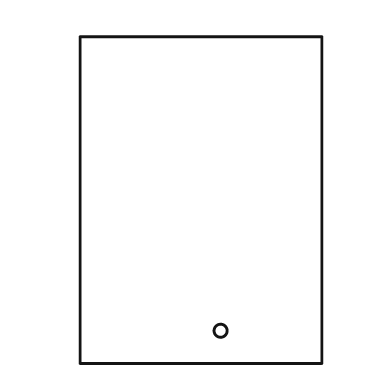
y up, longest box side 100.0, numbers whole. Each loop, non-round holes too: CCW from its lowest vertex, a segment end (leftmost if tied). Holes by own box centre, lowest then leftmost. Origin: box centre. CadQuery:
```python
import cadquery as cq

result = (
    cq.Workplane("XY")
    .moveTo(-37.0, -50.0)
    .lineTo(37.0, -50.0)
    .lineTo(37.0, 50.0)
    .lineTo(-37.0, 50.0)
    .close()
    .moveTo(6.0, -40.0)
    .circle(2.0)
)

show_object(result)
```